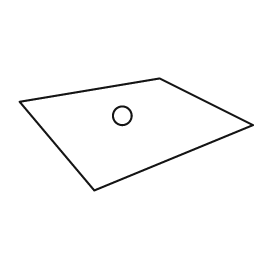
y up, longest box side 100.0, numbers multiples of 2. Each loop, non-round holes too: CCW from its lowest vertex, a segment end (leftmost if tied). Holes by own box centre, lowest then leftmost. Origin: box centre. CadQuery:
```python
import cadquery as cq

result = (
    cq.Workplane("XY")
    .moveTo(-18.0, -24.0)
    .lineTo(50.0, 4.0)
    .lineTo(10.0, 24.0)
    .lineTo(-50.0, 14.0)
    .close()
    .moveTo(-6.0, 8.0)
    .circle(4.0)
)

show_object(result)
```